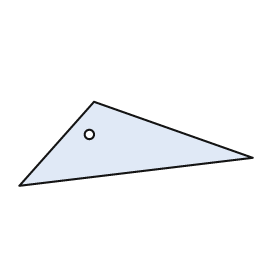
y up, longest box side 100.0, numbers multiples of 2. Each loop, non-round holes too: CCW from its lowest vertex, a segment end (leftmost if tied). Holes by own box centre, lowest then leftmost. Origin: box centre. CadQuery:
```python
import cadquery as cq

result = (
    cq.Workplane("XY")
    .moveTo(-50.0, -18.0)
    .lineTo(50.0, -6.0)
    .lineTo(-18.0, 18.0)
    .close()
    .moveTo(-20.0, 4.0)
    .circle(2.0)
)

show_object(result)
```